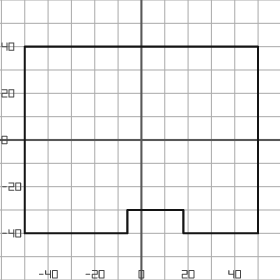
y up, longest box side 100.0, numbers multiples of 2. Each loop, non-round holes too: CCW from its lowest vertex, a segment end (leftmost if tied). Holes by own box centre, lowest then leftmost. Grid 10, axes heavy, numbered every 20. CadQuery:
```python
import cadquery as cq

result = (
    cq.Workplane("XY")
    .moveTo(-50.0, -40.0)
    .lineTo(-6.0, -40.0)
    .lineTo(-6.0, -30.0)
    .lineTo(18.0, -30.0)
    .lineTo(18.0, -40.0)
    .lineTo(50.0, -40.0)
    .lineTo(50.0, 40.0)
    .lineTo(-50.0, 40.0)
    .close()
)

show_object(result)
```